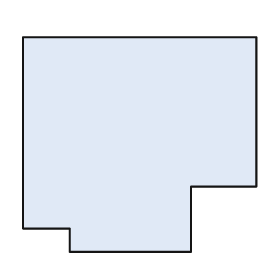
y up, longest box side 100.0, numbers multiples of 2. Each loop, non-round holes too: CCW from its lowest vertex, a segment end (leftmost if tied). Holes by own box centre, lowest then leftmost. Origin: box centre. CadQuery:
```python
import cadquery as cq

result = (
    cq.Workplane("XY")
    .moveTo(-30.0, -46.0)
    .lineTo(22.0, -46.0)
    .lineTo(22.0, -18.0)
    .lineTo(50.0, -18.0)
    .lineTo(50.0, 46.0)
    .lineTo(-50.0, 46.0)
    .lineTo(-50.0, -36.0)
    .lineTo(-30.0, -36.0)
    .close()
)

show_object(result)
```